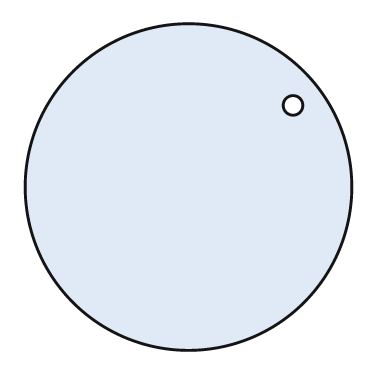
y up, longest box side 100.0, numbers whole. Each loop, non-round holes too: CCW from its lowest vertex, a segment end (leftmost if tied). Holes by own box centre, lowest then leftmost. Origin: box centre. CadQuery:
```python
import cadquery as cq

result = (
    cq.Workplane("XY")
    .moveTo(0.0, 0.0)
    .circle(50.0)
    .moveTo(32.0, 25.0)
    .circle(3.0)
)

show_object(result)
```